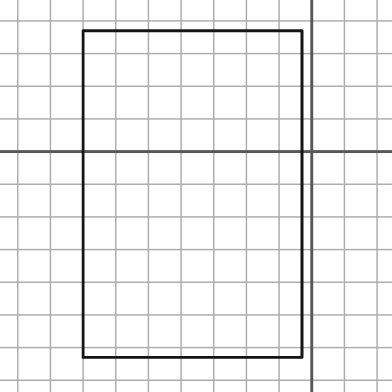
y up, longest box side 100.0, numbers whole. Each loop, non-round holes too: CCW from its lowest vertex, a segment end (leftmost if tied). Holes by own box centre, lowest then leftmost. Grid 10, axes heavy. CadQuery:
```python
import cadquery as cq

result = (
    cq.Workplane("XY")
    .moveTo(-70.0, -63.0)
    .lineTo(-3.0, -63.0)
    .lineTo(-3.0, 37.0)
    .lineTo(-70.0, 37.0)
    .close()
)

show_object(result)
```